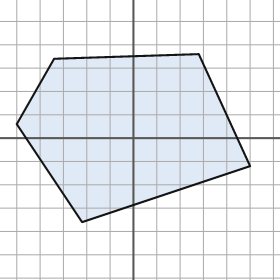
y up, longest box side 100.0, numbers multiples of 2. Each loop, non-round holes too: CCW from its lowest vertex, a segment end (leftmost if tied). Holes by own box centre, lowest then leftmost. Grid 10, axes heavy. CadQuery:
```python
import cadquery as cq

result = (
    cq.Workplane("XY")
    .moveTo(-22.0, -36.0)
    .lineTo(50.0, -12.0)
    .lineTo(28.0, 36.0)
    .lineTo(-34.0, 34.0)
    .lineTo(-50.0, 6.0)
    .close()
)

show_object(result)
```